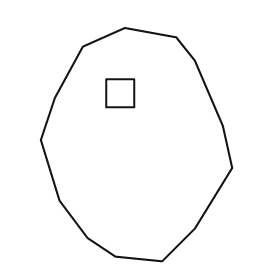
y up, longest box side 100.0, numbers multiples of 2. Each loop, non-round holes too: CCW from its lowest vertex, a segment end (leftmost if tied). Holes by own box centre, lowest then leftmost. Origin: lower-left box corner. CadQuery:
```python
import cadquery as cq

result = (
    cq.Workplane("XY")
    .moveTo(52.0, 0.0)
    .lineTo(66.0, 14.0)
    .lineTo(82.0, 40.0)
    .lineTo(78.0, 58.0)
    .lineTo(66.0, 86.0)
    .lineTo(58.0, 96.0)
    .lineTo(36.0, 100.0)
    .lineTo(18.0, 92.0)
    .lineTo(6.0, 70.0)
    .lineTo(0.0, 52.0)
    .lineTo(8.0, 26.0)
    .lineTo(20.0, 10.0)
    .lineTo(32.0, 2.0)
    .close()
    .moveTo(28.0, 66.0)
    .lineTo(40.0, 66.0)
    .lineTo(40.0, 78.0)
    .lineTo(28.0, 78.0)
    .close()
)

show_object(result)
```